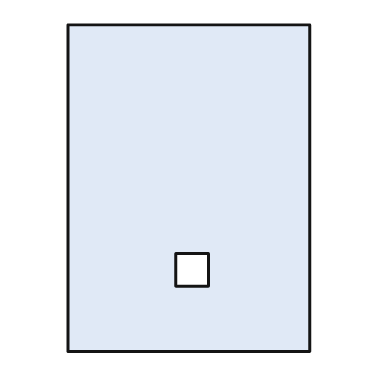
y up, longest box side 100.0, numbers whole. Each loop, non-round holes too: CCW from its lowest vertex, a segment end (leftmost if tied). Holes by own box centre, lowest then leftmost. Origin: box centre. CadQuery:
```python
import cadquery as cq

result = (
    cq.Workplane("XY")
    .moveTo(-37.0, -50.0)
    .lineTo(37.0, -50.0)
    .lineTo(37.0, 50.0)
    .lineTo(-37.0, 50.0)
    .close()
    .moveTo(-4.0, -30.0)
    .lineTo(6.0, -30.0)
    .lineTo(6.0, -20.0)
    .lineTo(-4.0, -20.0)
    .close()
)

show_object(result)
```